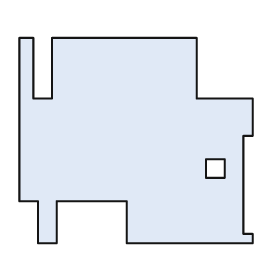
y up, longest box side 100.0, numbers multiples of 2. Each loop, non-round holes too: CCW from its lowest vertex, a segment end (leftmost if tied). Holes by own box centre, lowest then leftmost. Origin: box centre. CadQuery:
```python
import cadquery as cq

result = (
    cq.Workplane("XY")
    .moveTo(-42.0, -44.0)
    .lineTo(-34.0, -44.0)
    .lineTo(-34.0, -26.0)
    .lineTo(-4.0, -26.0)
    .lineTo(-4.0, -44.0)
    .lineTo(50.0, -44.0)
    .lineTo(50.0, -40.0)
    .lineTo(46.0, -40.0)
    .lineTo(46.0, 2.0)
    .lineTo(50.0, 2.0)
    .lineTo(50.0, 18.0)
    .lineTo(26.0, 18.0)
    .lineTo(26.0, 44.0)
    .lineTo(-36.0, 44.0)
    .lineTo(-36.0, 18.0)
    .lineTo(-44.0, 18.0)
    .lineTo(-44.0, 44.0)
    .lineTo(-50.0, 44.0)
    .lineTo(-50.0, -26.0)
    .lineTo(-42.0, -26.0)
    .close()
    .moveTo(30.0, -16.0)
    .lineTo(38.0, -16.0)
    .lineTo(38.0, -8.0)
    .lineTo(30.0, -8.0)
    .close()
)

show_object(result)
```